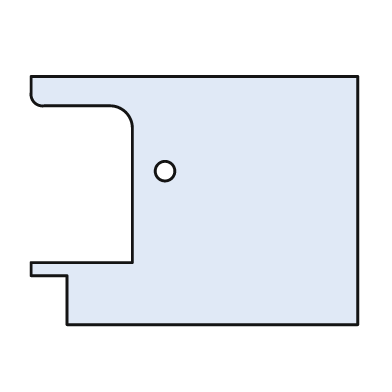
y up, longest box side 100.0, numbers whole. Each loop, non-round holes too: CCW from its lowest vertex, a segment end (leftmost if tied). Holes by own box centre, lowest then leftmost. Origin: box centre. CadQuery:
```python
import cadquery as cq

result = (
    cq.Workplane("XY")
    .moveTo(-39.0, -38.0)
    .lineTo(50.0, -38.0)
    .lineTo(50.0, 38.0)
    .lineTo(-50.0, 38.0)
    .lineTo(-50.0, 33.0)
    .threePointArc((-49.0, 30.0), (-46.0, 29.0))
    .lineTo(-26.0, 29.0)
    .threePointArc((-21.0, 27.0), (-19.0, 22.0))
    .lineTo(-19.0, -19.0)
    .lineTo(-50.0, -19.0)
    .lineTo(-50.0, -23.0)
    .lineTo(-39.0, -23.0)
    .close()
    .moveTo(-9.0, 9.0)
    .circle(3.0)
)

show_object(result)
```